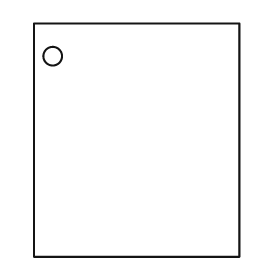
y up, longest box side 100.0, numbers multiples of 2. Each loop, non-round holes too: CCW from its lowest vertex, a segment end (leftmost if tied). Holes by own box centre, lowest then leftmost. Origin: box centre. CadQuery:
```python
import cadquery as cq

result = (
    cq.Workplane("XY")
    .moveTo(-44.0, -50.0)
    .lineTo(44.0, -50.0)
    .lineTo(44.0, 50.0)
    .lineTo(-44.0, 50.0)
    .close()
    .moveTo(-36.0, 36.0)
    .circle(4.0)
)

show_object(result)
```